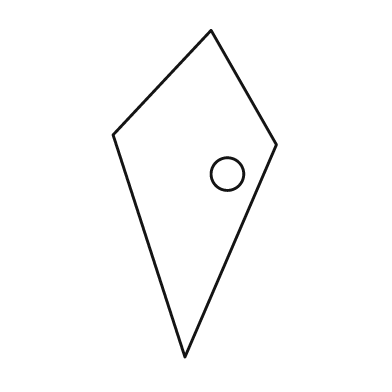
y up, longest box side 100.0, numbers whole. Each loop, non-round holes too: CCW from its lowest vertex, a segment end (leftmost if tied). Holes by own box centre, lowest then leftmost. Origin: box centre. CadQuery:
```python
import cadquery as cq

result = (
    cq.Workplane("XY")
    .moveTo(-3.0, -50.0)
    .lineTo(25.0, 15.0)
    .lineTo(5.0, 50.0)
    .lineTo(-25.0, 18.0)
    .close()
    .moveTo(10.0, 6.0)
    .circle(5.0)
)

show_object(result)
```